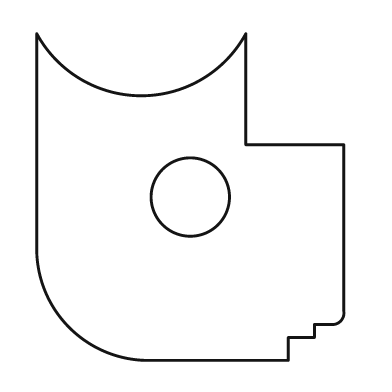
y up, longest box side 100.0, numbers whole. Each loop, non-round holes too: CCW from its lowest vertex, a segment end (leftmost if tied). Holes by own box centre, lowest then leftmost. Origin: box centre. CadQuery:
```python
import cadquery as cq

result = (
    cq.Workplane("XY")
    .moveTo(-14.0, -50.0)
    .lineTo(30.0, -50.0)
    .lineTo(30.0, -43.0)
    .lineTo(38.0, -43.0)
    .lineTo(38.0, -39.0)
    .lineTo(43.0, -39.0)
    .threePointArc((46.0, -38.0), (47.0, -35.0))
    .lineTo(47.0, 16.0)
    .lineTo(17.0, 16.0)
    .lineTo(17.0, 50.0)
    .threePointArc((-15.0, 31.0), (-47.0, 50.0))
    .lineTo(-47.0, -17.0)
    .threePointArc((-37.0, -40.0), (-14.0, -50.0))
    .close()
    .moveTo(0.0, 0.0)
    .circle(12.0)
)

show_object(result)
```